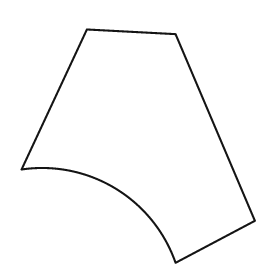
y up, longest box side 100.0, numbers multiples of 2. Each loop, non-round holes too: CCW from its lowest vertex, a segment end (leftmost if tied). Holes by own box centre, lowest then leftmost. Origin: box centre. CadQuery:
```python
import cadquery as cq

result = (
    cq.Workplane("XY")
    .moveTo(16.0, -50.0)
    .lineTo(50.0, -32.0)
    .lineTo(16.0, 48.0)
    .lineTo(-22.0, 50.0)
    .lineTo(-50.0, -10.0)
    .threePointArc((-10.0, -18.0), (16.0, -50.0))
    .close()
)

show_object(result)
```